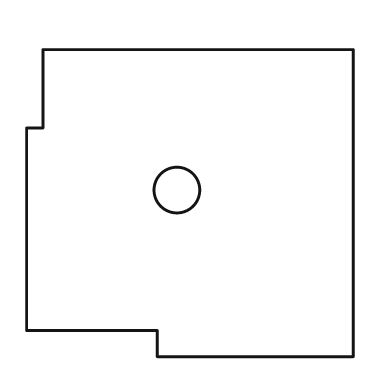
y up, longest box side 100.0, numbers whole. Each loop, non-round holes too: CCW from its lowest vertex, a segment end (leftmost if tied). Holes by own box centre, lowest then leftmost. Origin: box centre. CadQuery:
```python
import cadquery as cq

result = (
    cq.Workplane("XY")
    .moveTo(-10.0, -47.0)
    .lineTo(50.0, -47.0)
    .lineTo(50.0, 47.0)
    .lineTo(-45.0, 47.0)
    .lineTo(-45.0, 23.0)
    .lineTo(-50.0, 23.0)
    .lineTo(-50.0, -39.0)
    .lineTo(-10.0, -39.0)
    .close()
    .moveTo(-4.0, 4.0)
    .circle(7.0)
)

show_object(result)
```